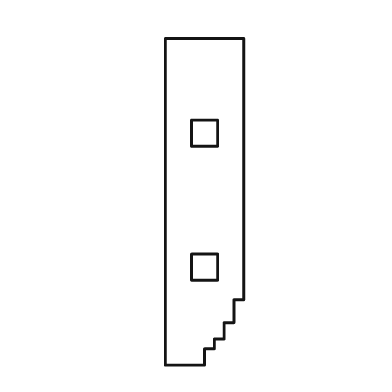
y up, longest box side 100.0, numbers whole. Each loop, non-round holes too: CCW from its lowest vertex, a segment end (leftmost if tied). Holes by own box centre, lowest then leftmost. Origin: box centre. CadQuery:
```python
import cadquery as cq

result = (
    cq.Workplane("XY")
    .moveTo(-12.0, -50.0)
    .lineTo(0.0, -50.0)
    .lineTo(0.0, -45.0)
    .lineTo(3.0, -45.0)
    .lineTo(3.0, -42.0)
    .lineTo(6.0, -42.0)
    .lineTo(6.0, -37.0)
    .lineTo(9.0, -37.0)
    .lineTo(9.0, -30.0)
    .lineTo(12.0, -30.0)
    .lineTo(12.0, 50.0)
    .lineTo(-12.0, 50.0)
    .close()
    .moveTo(-4.0, -24.0)
    .lineTo(4.0, -24.0)
    .lineTo(4.0, -16.0)
    .lineTo(-4.0, -16.0)
    .close()
    .moveTo(-4.0, 17.0)
    .lineTo(4.0, 17.0)
    .lineTo(4.0, 25.0)
    .lineTo(-4.0, 25.0)
    .close()
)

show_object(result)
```